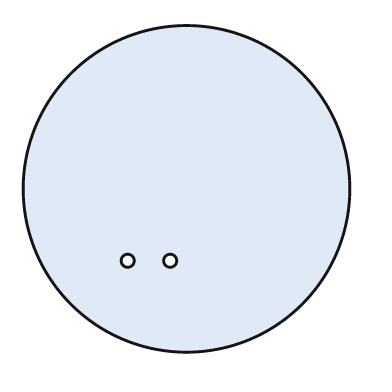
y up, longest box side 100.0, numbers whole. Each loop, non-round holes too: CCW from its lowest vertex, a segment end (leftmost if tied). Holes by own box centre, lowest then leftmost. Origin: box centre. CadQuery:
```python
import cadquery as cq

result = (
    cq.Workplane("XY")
    .moveTo(0.0, 0.0)
    .circle(50.0)
    .moveTo(-18.0, -22.0)
    .circle(2.0)
    .moveTo(-5.0, -22.0)
    .circle(2.0)
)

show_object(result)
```